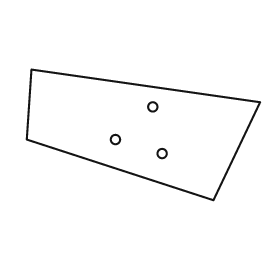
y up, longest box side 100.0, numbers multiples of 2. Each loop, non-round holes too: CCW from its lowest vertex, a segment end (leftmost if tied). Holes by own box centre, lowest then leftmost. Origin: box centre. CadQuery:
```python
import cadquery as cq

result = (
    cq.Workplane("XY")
    .moveTo(30.0, -28.0)
    .lineTo(50.0, 14.0)
    .lineTo(-48.0, 28.0)
    .lineTo(-50.0, -2.0)
    .close()
    .moveTo(8.0, -8.0)
    .circle(2.0)
    .moveTo(-12.0, -2.0)
    .circle(2.0)
    .moveTo(4.0, 12.0)
    .circle(2.0)
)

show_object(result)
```